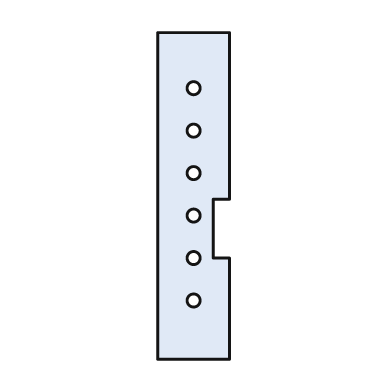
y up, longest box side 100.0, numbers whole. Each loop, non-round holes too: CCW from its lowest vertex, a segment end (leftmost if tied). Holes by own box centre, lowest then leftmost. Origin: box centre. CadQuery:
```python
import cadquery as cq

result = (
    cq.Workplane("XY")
    .moveTo(-11.0, -50.0)
    .lineTo(11.0, -50.0)
    .lineTo(11.0, -19.0)
    .lineTo(6.0, -19.0)
    .lineTo(6.0, -1.0)
    .lineTo(11.0, -1.0)
    .lineTo(11.0, 50.0)
    .lineTo(-11.0, 50.0)
    .close()
    .moveTo(0.0, -32.0)
    .circle(2.0)
    .moveTo(0.0, -19.0)
    .circle(2.0)
    .moveTo(0.0, -6.0)
    .circle(2.0)
    .moveTo(0.0, 7.0)
    .circle(2.0)
    .moveTo(0.0, 20.0)
    .circle(2.0)
    .moveTo(0.0, 33.0)
    .circle(2.0)
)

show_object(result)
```